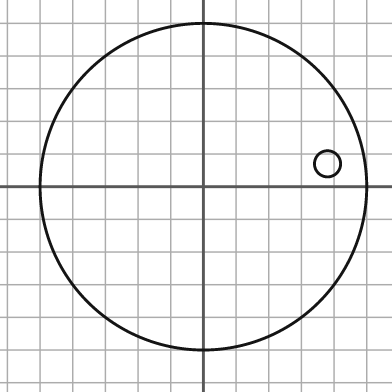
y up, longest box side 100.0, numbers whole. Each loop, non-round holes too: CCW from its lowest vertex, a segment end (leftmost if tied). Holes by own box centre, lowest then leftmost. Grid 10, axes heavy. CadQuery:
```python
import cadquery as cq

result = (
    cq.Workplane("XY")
    .moveTo(0.0, 0.0)
    .circle(50.0)
    .moveTo(38.0, 7.0)
    .circle(4.0)
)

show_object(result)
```